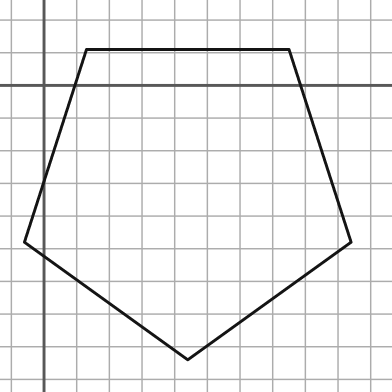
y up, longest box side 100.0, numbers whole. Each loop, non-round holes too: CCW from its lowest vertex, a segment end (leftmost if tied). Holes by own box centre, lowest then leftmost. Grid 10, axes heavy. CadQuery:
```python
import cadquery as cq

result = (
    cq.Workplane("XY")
    .moveTo(44.0, -84.0)
    .lineTo(94.0, -48.0)
    .lineTo(75.0, 11.0)
    .lineTo(13.0, 11.0)
    .lineTo(-6.0, -48.0)
    .close()
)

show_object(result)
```